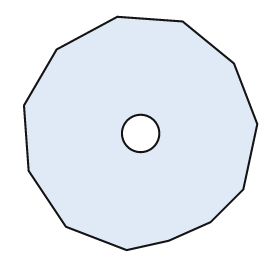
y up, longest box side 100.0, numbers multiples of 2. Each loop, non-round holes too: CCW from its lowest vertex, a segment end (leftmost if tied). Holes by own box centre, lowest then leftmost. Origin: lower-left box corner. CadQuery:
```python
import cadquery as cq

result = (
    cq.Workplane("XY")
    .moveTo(44.0, 0.0)
    .lineTo(62.0, 4.0)
    .lineTo(80.0, 12.0)
    .lineTo(94.0, 26.0)
    .lineTo(100.0, 54.0)
    .lineTo(90.0, 80.0)
    .lineTo(68.0, 98.0)
    .lineTo(40.0, 100.0)
    .lineTo(14.0, 86.0)
    .lineTo(0.0, 62.0)
    .lineTo(2.0, 34.0)
    .lineTo(18.0, 10.0)
    .close()
    .moveTo(50.0, 50.0)
    .circle(8.0)
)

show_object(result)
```